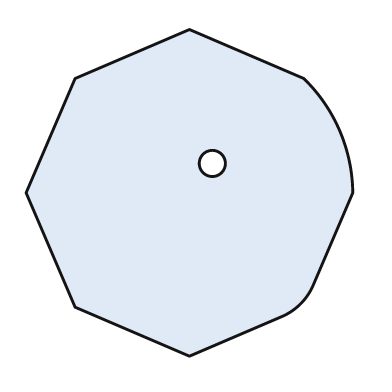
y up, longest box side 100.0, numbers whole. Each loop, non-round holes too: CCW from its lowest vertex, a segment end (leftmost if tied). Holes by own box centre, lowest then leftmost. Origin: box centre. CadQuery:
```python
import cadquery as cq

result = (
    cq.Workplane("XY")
    .moveTo(0.0, -50.0)
    .lineTo(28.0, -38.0)
    .threePointArc((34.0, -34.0), (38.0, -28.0))
    .lineTo(50.0, 0.0)
    .threePointArc((46.0, 19.0), (35.0, 35.0))
    .lineTo(0.0, 50.0)
    .lineTo(-35.0, 35.0)
    .lineTo(-50.0, 0.0)
    .lineTo(-35.0, -35.0)
    .close()
    .moveTo(7.0, 9.0)
    .circle(4.0)
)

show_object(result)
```